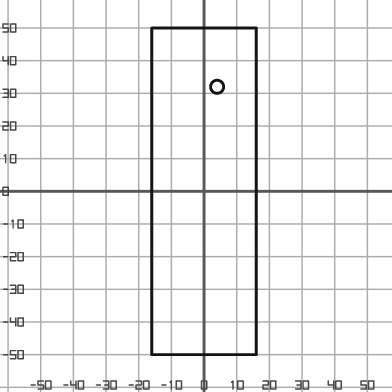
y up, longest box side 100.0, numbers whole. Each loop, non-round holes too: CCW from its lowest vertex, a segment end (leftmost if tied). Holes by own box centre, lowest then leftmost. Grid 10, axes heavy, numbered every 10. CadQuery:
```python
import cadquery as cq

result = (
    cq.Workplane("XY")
    .moveTo(-16.0, -50.0)
    .lineTo(16.0, -50.0)
    .lineTo(16.0, 50.0)
    .lineTo(-16.0, 50.0)
    .close()
    .moveTo(4.0, 32.0)
    .circle(2.0)
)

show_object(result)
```